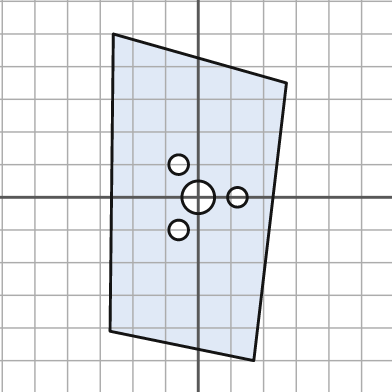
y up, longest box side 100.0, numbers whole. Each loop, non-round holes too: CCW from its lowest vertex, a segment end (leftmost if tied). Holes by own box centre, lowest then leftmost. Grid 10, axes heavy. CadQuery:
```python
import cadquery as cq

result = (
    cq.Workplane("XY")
    .moveTo(17.0, -50.0)
    .lineTo(27.0, 35.0)
    .lineTo(-26.0, 50.0)
    .lineTo(-27.0, -41.0)
    .close()
    .moveTo(-6.0, -10.0)
    .circle(3.0)
    .moveTo(0.0, 0.0)
    .circle(5.0)
    .moveTo(12.0, 0.0)
    .circle(3.0)
    .moveTo(-6.0, 10.0)
    .circle(3.0)
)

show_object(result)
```